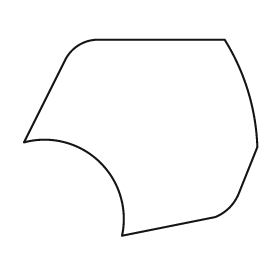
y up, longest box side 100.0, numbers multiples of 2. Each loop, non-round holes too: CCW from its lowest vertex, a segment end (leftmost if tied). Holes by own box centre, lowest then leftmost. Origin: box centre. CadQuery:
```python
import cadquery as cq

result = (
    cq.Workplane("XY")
    .moveTo(-8.0, -42.0)
    .lineTo(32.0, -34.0)
    .threePointArc((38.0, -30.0), (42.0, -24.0))
    .lineTo(50.0, -4.0)
    .threePointArc((46.0, 20.0), (36.0, 42.0))
    .lineTo(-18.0, 42.0)
    .threePointArc((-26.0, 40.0), (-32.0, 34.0))
    .lineTo(-50.0, -2.0)
    .threePointArc((-18.0, -10.0), (-8.0, -42.0))
    .close()
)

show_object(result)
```